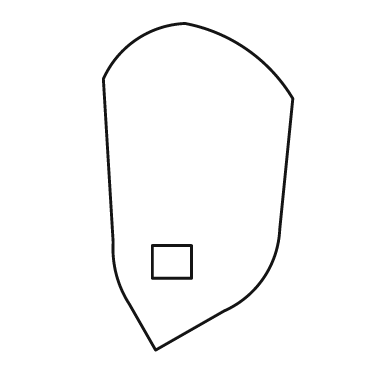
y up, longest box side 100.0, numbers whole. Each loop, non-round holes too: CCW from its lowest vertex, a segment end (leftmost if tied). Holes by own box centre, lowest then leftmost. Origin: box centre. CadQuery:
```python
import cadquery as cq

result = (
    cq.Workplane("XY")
    .moveTo(-13.0, -50.0)
    .lineTo(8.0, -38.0)
    .threePointArc((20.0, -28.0), (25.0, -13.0))
    .lineTo(29.0, 27.0)
    .threePointArc((15.0, 42.0), (-4.0, 50.0))
    .threePointArc((-19.0, 45.0), (-29.0, 33.0))
    .lineTo(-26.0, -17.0)
    .threePointArc((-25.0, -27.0), (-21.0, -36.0))
    .close()
    .moveTo(-14.0, -28.0)
    .lineTo(-2.0, -28.0)
    .lineTo(-2.0, -18.0)
    .lineTo(-14.0, -18.0)
    .close()
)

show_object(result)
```